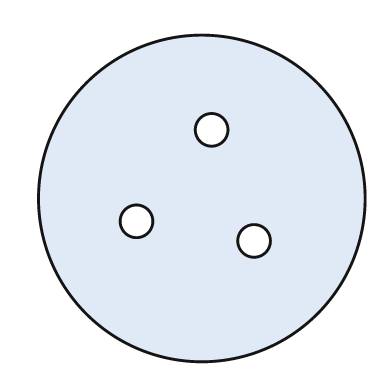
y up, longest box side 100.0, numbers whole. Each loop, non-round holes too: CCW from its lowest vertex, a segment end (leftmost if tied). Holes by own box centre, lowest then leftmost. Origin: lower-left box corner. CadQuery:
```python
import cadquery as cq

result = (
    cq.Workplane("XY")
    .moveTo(50.0, 50.0)
    .circle(50.0)
    .moveTo(66.0, 37.0)
    .circle(5.0)
    .moveTo(30.0, 43.0)
    .circle(5.0)
    .moveTo(53.0, 71.0)
    .circle(5.0)
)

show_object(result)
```